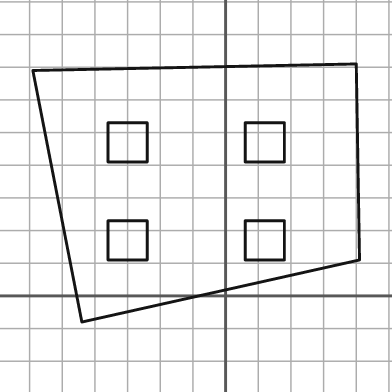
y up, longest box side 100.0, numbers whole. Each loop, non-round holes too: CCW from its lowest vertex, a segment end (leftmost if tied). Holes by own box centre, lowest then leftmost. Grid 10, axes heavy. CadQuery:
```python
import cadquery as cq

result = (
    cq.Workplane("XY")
    .moveTo(-44.0, -8.0)
    .lineTo(41.0, 11.0)
    .lineTo(40.0, 71.0)
    .lineTo(-59.0, 69.0)
    .close()
    .moveTo(-36.0, 11.0)
    .lineTo(-24.0, 11.0)
    .lineTo(-24.0, 23.0)
    .lineTo(-36.0, 23.0)
    .close()
    .moveTo(6.0, 11.0)
    .lineTo(18.0, 11.0)
    .lineTo(18.0, 23.0)
    .lineTo(6.0, 23.0)
    .close()
    .moveTo(-36.0, 41.0)
    .lineTo(-24.0, 41.0)
    .lineTo(-24.0, 53.0)
    .lineTo(-36.0, 53.0)
    .close()
    .moveTo(6.0, 41.0)
    .lineTo(18.0, 41.0)
    .lineTo(18.0, 53.0)
    .lineTo(6.0, 53.0)
    .close()
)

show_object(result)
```